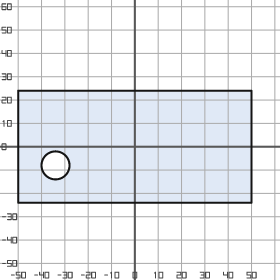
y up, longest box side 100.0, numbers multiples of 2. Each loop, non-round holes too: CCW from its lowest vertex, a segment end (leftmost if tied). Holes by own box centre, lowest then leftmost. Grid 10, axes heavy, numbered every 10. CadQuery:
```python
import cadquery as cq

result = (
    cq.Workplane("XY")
    .moveTo(-50.0, -24.0)
    .lineTo(50.0, -24.0)
    .lineTo(50.0, 24.0)
    .lineTo(-50.0, 24.0)
    .close()
    .moveTo(-34.0, -8.0)
    .circle(6.0)
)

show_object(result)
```